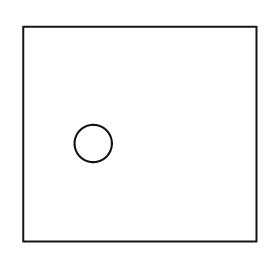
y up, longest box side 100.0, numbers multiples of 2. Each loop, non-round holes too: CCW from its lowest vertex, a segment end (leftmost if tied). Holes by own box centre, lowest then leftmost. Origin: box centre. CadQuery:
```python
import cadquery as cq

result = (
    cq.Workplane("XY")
    .moveTo(-50.0, -46.0)
    .lineTo(50.0, -46.0)
    .lineTo(50.0, 46.0)
    .lineTo(-50.0, 46.0)
    .close()
    .moveTo(-20.0, -4.0)
    .circle(8.0)
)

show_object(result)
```